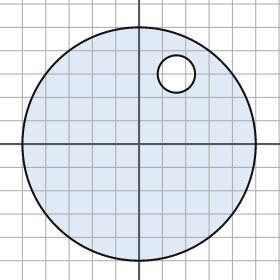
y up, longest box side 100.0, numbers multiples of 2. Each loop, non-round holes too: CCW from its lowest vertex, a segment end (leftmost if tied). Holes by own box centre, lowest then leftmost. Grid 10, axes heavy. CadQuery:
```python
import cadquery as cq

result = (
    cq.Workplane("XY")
    .moveTo(0.0, 0.0)
    .circle(50.0)
    .moveTo(16.0, 30.0)
    .circle(8.0)
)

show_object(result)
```